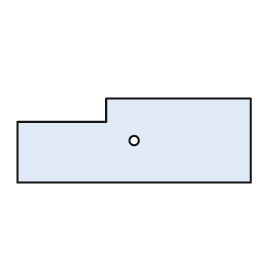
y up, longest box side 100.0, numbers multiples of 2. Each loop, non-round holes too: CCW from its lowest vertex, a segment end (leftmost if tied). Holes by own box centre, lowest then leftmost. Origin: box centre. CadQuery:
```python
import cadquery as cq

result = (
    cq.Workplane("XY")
    .moveTo(-50.0, -18.0)
    .lineTo(50.0, -18.0)
    .lineTo(50.0, 18.0)
    .lineTo(-12.0, 18.0)
    .lineTo(-12.0, 8.0)
    .lineTo(-50.0, 8.0)
    .close()
    .moveTo(0.0, 0.0)
    .circle(2.0)
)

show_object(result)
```